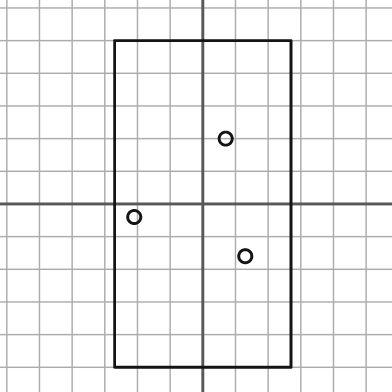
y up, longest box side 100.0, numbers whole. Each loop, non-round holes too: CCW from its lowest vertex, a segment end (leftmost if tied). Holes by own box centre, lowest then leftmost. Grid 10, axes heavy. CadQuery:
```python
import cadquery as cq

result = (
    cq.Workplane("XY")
    .moveTo(-27.0, -50.0)
    .lineTo(27.0, -50.0)
    .lineTo(27.0, 50.0)
    .lineTo(-27.0, 50.0)
    .close()
    .moveTo(13.0, -16.0)
    .circle(2.0)
    .moveTo(-21.0, -4.0)
    .circle(2.0)
    .moveTo(7.0, 20.0)
    .circle(2.0)
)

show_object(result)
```